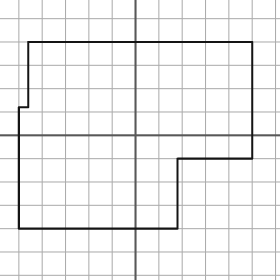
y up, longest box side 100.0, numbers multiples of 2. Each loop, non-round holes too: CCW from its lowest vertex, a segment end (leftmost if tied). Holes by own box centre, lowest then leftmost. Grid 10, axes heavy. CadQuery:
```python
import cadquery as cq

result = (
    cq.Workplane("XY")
    .moveTo(-50.0, -40.0)
    .lineTo(18.0, -40.0)
    .lineTo(18.0, -10.0)
    .lineTo(50.0, -10.0)
    .lineTo(50.0, 40.0)
    .lineTo(-46.0, 40.0)
    .lineTo(-46.0, 12.0)
    .lineTo(-50.0, 12.0)
    .close()
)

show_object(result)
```